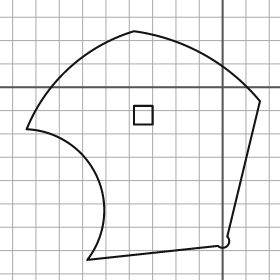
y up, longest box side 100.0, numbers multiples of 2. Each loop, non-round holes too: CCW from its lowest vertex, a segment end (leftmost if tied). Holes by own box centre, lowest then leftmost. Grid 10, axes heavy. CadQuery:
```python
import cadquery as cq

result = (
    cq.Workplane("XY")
    .moveTo(-58.0, -74.0)
    .lineTo(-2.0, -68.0)
    .threePointArc((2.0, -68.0), (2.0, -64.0))
    .lineTo(16.0, -6.0)
    .threePointArc((-8.0, 14.0), (-38.0, 24.0))
    .threePointArc((-66.0, 8.0), (-84.0, -18.0))
    .threePointArc((-54.0, -38.0), (-58.0, -74.0))
    .close()
    .moveTo(-38.0, -16.0)
    .lineTo(-30.0, -16.0)
    .lineTo(-30.0, -8.0)
    .lineTo(-38.0, -8.0)
    .close()
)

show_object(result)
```